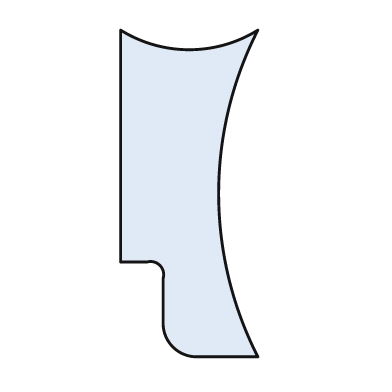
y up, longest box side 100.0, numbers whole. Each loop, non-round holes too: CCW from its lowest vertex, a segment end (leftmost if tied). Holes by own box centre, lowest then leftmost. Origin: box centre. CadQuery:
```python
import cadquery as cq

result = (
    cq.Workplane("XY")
    .moveTo(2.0, -50.0)
    .lineTo(21.0, -50.0)
    .threePointArc((9.0, 0.0), (21.0, 50.0))
    .threePointArc((0.0, 44.0), (-21.0, 50.0))
    .lineTo(-21.0, -21.0)
    .lineTo(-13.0, -21.0)
    .threePointArc((-9.0, -22.0), (-8.0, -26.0))
    .lineTo(-8.0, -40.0)
    .threePointArc((-5.0, -47.0), (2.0, -50.0))
    .close()
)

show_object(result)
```